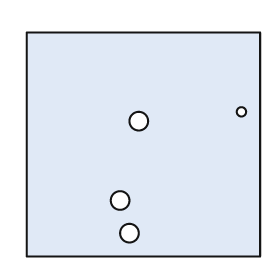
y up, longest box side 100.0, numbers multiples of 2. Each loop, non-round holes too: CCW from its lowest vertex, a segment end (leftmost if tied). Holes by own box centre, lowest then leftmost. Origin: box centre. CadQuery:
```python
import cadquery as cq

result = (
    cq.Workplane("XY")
    .moveTo(-50.0, -48.0)
    .lineTo(50.0, -48.0)
    .lineTo(50.0, 48.0)
    .lineTo(-50.0, 48.0)
    .close()
    .moveTo(-6.0, -38.0)
    .circle(4.0)
    .moveTo(-10.0, -24.0)
    .circle(4.0)
    .moveTo(-2.0, 10.0)
    .circle(4.0)
    .moveTo(42.0, 14.0)
    .circle(2.0)
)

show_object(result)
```